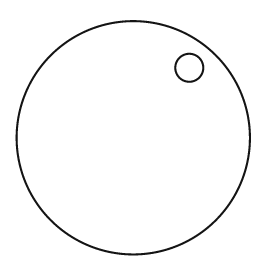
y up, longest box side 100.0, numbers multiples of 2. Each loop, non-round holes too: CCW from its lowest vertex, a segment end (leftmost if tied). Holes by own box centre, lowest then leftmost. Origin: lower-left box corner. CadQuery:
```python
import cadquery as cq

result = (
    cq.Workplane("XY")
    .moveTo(50.0, 50.0)
    .circle(50.0)
    .moveTo(74.0, 80.0)
    .circle(6.0)
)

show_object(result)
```